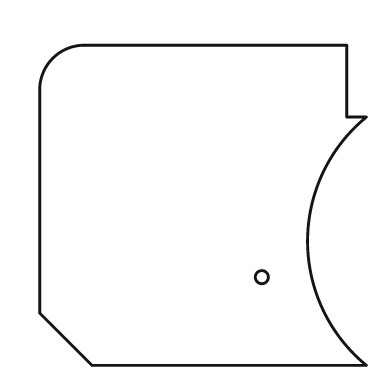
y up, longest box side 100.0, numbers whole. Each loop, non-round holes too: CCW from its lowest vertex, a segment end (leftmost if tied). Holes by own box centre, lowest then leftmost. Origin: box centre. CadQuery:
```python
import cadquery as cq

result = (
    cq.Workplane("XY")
    .moveTo(-34.0, -49.0)
    .lineTo(50.0, -49.0)
    .threePointArc((32.0, -11.0), (50.0, 27.0))
    .lineTo(44.0, 27.0)
    .lineTo(44.0, 49.0)
    .lineTo(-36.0, 49.0)
    .threePointArc((-46.0, 45.0), (-50.0, 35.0))
    .lineTo(-50.0, -33.0)
    .close()
    .moveTo(18.0, -22.0)
    .circle(2.0)
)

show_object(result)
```